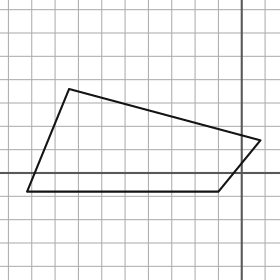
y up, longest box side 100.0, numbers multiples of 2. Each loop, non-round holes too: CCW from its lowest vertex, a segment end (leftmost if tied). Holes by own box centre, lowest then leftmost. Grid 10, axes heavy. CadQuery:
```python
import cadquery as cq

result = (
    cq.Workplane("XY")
    .moveTo(-92.0, -8.0)
    .lineTo(-10.0, -8.0)
    .lineTo(8.0, 14.0)
    .lineTo(-74.0, 36.0)
    .close()
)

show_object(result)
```